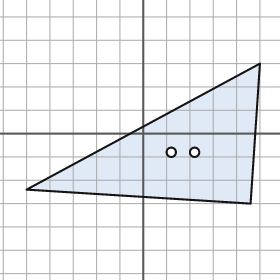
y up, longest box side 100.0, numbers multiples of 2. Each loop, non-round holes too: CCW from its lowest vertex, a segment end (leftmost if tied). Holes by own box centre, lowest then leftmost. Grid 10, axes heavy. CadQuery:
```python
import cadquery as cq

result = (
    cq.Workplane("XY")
    .moveTo(46.0, -30.0)
    .lineTo(50.0, 30.0)
    .lineTo(-50.0, -24.0)
    .close()
    .moveTo(12.0, -8.0)
    .circle(2.0)
    .moveTo(22.0, -8.0)
    .circle(2.0)
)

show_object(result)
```